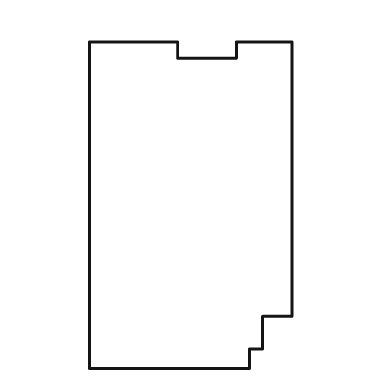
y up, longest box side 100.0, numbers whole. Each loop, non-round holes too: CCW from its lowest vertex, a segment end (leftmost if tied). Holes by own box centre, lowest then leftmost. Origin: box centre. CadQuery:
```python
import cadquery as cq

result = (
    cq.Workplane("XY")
    .moveTo(-31.0, -50.0)
    .lineTo(18.0, -50.0)
    .lineTo(18.0, -44.0)
    .lineTo(22.0, -44.0)
    .lineTo(22.0, -34.0)
    .lineTo(31.0, -34.0)
    .lineTo(31.0, 50.0)
    .lineTo(14.0, 50.0)
    .lineTo(14.0, 45.0)
    .lineTo(-4.0, 45.0)
    .lineTo(-4.0, 50.0)
    .lineTo(-31.0, 50.0)
    .close()
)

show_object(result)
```